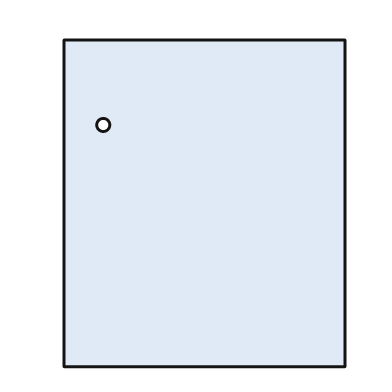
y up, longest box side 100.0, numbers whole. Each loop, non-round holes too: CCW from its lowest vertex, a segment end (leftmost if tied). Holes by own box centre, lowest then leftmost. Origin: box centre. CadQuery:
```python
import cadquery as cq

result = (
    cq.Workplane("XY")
    .moveTo(-43.0, -50.0)
    .lineTo(43.0, -50.0)
    .lineTo(43.0, 50.0)
    .lineTo(-43.0, 50.0)
    .close()
    .moveTo(-31.0, 24.0)
    .circle(2.0)
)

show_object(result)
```